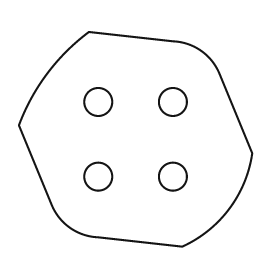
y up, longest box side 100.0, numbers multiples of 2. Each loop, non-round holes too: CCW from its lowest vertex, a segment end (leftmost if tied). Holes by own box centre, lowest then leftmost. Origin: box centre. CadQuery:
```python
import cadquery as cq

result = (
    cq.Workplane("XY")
    .moveTo(20.0, -46.0)
    .threePointArc((40.0, -30.0), (50.0, -6.0))
    .lineTo(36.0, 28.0)
    .threePointArc((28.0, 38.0), (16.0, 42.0))
    .lineTo(-20.0, 46.0)
    .threePointArc((-38.0, 28.0), (-50.0, 6.0))
    .lineTo(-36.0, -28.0)
    .threePointArc((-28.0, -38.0), (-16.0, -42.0))
    .close()
    .moveTo(-16.0, -16.0)
    .circle(6.0)
    .moveTo(16.0, -16.0)
    .circle(6.0)
    .moveTo(-16.0, 16.0)
    .circle(6.0)
    .moveTo(16.0, 16.0)
    .circle(6.0)
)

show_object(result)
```